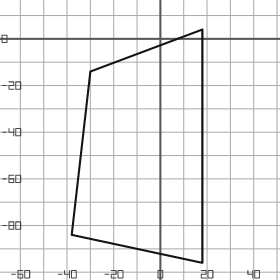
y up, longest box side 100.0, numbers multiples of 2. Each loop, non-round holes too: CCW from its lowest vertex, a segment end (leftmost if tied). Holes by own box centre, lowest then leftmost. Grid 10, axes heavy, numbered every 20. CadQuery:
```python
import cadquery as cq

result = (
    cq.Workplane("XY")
    .moveTo(18.0, -96.0)
    .lineTo(18.0, 4.0)
    .lineTo(-30.0, -14.0)
    .lineTo(-38.0, -84.0)
    .close()
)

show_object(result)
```